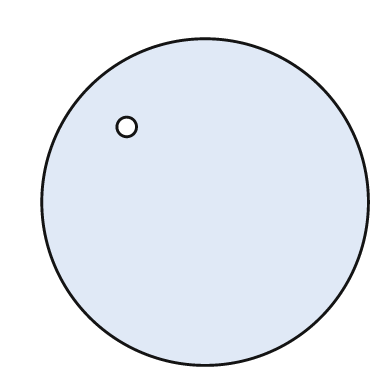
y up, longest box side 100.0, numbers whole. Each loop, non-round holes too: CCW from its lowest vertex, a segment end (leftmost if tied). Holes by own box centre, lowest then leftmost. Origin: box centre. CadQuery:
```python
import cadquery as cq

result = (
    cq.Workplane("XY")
    .moveTo(0.0, 0.0)
    .circle(50.0)
    .moveTo(-24.0, 23.0)
    .circle(3.0)
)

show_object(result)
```